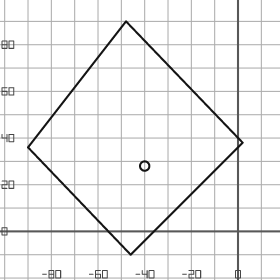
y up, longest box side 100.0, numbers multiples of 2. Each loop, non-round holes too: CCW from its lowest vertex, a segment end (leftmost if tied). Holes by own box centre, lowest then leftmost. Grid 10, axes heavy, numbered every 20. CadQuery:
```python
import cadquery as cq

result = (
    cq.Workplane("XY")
    .moveTo(-46.0, -10.0)
    .lineTo(2.0, 38.0)
    .lineTo(-48.0, 90.0)
    .lineTo(-90.0, 36.0)
    .close()
    .moveTo(-40.0, 28.0)
    .circle(2.0)
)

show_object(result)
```